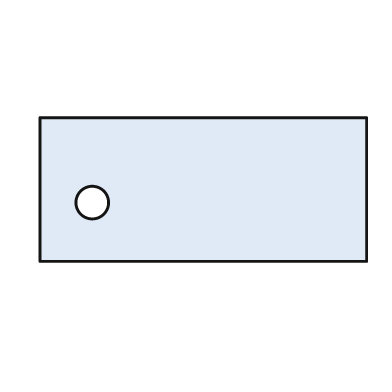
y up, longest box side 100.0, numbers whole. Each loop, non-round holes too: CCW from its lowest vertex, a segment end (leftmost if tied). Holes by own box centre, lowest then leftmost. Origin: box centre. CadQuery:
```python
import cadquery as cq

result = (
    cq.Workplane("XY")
    .moveTo(-50.0, -22.0)
    .lineTo(50.0, -22.0)
    .lineTo(50.0, 22.0)
    .lineTo(-50.0, 22.0)
    .close()
    .moveTo(-34.0, -4.0)
    .circle(5.0)
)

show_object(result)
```